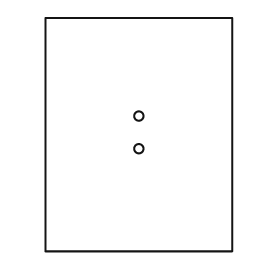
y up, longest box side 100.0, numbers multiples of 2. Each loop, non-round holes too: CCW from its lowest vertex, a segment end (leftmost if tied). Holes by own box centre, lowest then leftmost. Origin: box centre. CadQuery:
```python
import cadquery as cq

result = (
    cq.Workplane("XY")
    .moveTo(-40.0, -50.0)
    .lineTo(40.0, -50.0)
    .lineTo(40.0, 50.0)
    .lineTo(-40.0, 50.0)
    .close()
    .moveTo(0.0, -6.0)
    .circle(2.0)
    .moveTo(0.0, 8.0)
    .circle(2.0)
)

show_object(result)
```